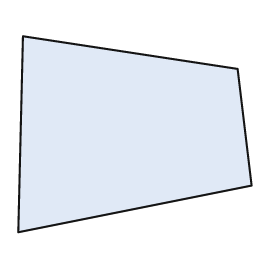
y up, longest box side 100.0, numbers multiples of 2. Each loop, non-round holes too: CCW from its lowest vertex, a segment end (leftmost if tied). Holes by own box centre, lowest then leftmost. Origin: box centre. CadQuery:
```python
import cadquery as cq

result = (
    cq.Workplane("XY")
    .moveTo(-50.0, -42.0)
    .lineTo(50.0, -22.0)
    .lineTo(44.0, 28.0)
    .lineTo(-48.0, 42.0)
    .close()
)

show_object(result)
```